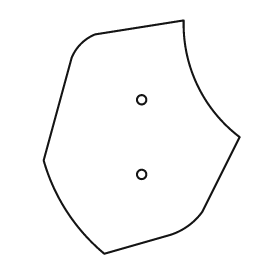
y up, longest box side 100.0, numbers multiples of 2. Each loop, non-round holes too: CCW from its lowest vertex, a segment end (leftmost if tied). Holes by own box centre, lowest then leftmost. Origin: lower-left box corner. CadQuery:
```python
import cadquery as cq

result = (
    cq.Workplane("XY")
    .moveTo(26.0, 0.0)
    .lineTo(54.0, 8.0)
    .threePointArc((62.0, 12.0), (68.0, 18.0))
    .lineTo(84.0, 50.0)
    .threePointArc((66.0, 72.0), (60.0, 100.0))
    .lineTo(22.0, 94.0)
    .threePointArc((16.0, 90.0), (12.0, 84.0))
    .lineTo(0.0, 40.0)
    .threePointArc((10.0, 18.0), (26.0, 0.0))
    .close()
    .moveTo(42.0, 34.0)
    .circle(2.0)
    .moveTo(42.0, 66.0)
    .circle(2.0)
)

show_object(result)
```